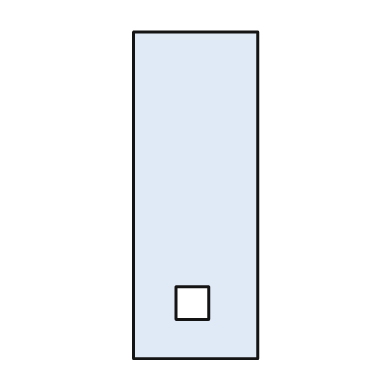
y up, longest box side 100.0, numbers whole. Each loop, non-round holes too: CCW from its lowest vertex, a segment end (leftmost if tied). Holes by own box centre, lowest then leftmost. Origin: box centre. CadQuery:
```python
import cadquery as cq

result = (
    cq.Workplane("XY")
    .moveTo(-19.0, -50.0)
    .lineTo(19.0, -50.0)
    .lineTo(19.0, 50.0)
    .lineTo(-19.0, 50.0)
    .close()
    .moveTo(-6.0, -38.0)
    .lineTo(4.0, -38.0)
    .lineTo(4.0, -28.0)
    .lineTo(-6.0, -28.0)
    .close()
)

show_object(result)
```